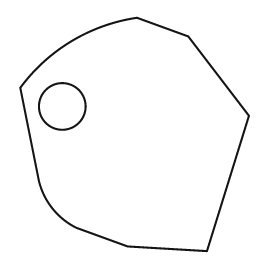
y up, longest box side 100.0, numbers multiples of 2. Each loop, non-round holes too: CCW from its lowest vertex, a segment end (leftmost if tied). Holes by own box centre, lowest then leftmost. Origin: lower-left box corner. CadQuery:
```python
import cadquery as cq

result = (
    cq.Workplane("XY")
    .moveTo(80.0, 0.0)
    .lineTo(98.0, 58.0)
    .lineTo(72.0, 92.0)
    .lineTo(50.0, 100.0)
    .threePointArc((22.0, 90.0), (0.0, 70.0))
    .lineTo(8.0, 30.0)
    .threePointArc((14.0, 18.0), (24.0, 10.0))
    .lineTo(46.0, 2.0)
    .close()
    .moveTo(18.0, 62.0)
    .circle(10.0)
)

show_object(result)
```